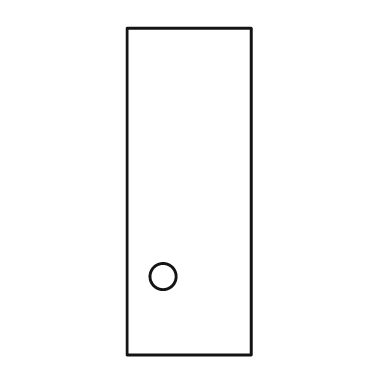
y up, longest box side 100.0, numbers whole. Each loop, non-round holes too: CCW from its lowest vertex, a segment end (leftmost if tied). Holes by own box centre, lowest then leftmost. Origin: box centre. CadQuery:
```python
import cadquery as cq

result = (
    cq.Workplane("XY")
    .moveTo(-19.0, -50.0)
    .lineTo(19.0, -50.0)
    .lineTo(19.0, 50.0)
    .lineTo(-19.0, 50.0)
    .close()
    .moveTo(-8.0, -26.0)
    .circle(4.0)
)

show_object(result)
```